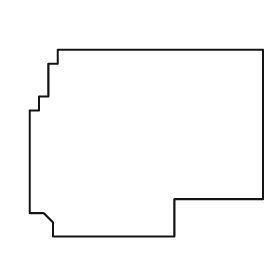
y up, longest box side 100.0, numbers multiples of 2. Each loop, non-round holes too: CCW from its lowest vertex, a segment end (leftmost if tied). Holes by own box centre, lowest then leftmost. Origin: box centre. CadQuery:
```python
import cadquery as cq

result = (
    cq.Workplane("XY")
    .moveTo(-40.0, -40.0)
    .lineTo(12.0, -40.0)
    .lineTo(12.0, -24.0)
    .lineTo(50.0, -24.0)
    .lineTo(50.0, 40.0)
    .lineTo(-38.0, 40.0)
    .lineTo(-38.0, 34.0)
    .lineTo(-42.0, 34.0)
    .lineTo(-42.0, 20.0)
    .lineTo(-46.0, 20.0)
    .lineTo(-46.0, 14.0)
    .lineTo(-50.0, 14.0)
    .lineTo(-50.0, -30.0)
    .lineTo(-44.0, -30.0)
    .lineTo(-40.0, -34.0)
    .close()
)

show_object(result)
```